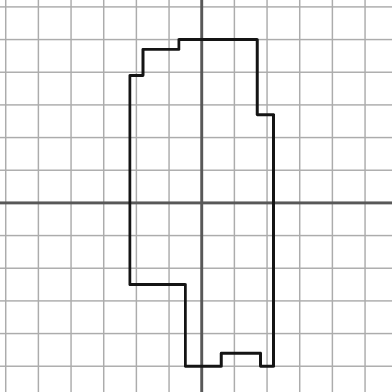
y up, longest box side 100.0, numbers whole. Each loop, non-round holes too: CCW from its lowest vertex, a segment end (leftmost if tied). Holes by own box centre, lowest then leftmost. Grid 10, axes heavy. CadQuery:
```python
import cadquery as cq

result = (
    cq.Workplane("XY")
    .moveTo(-5.0, -50.0)
    .lineTo(6.0, -50.0)
    .lineTo(6.0, -46.0)
    .lineTo(18.0, -46.0)
    .lineTo(18.0, -50.0)
    .lineTo(22.0, -50.0)
    .lineTo(22.0, 27.0)
    .lineTo(17.0, 27.0)
    .lineTo(17.0, 50.0)
    .lineTo(-7.0, 50.0)
    .lineTo(-7.0, 47.0)
    .lineTo(-18.0, 47.0)
    .lineTo(-18.0, 39.0)
    .lineTo(-22.0, 39.0)
    .lineTo(-22.0, -25.0)
    .lineTo(-5.0, -25.0)
    .close()
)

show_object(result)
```